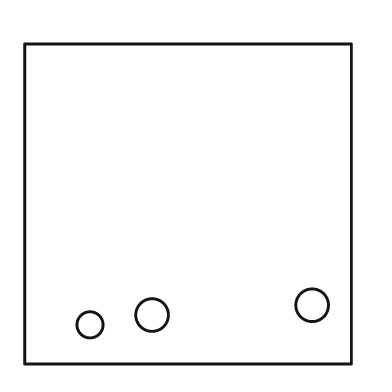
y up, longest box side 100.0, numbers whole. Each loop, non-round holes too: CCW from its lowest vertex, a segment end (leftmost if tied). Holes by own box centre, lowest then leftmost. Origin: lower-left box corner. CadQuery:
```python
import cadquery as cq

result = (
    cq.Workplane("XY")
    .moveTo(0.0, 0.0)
    .lineTo(100.0, 0.0)
    .lineTo(100.0, 98.0)
    .lineTo(0.0, 98.0)
    .close()
    .moveTo(20.0, 12.0)
    .circle(4.0)
    .moveTo(39.0, 15.0)
    .circle(5.0)
    .moveTo(88.0, 18.0)
    .circle(5.0)
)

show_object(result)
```